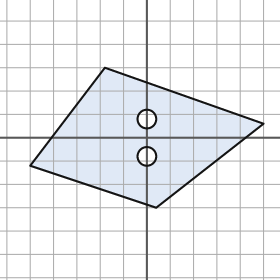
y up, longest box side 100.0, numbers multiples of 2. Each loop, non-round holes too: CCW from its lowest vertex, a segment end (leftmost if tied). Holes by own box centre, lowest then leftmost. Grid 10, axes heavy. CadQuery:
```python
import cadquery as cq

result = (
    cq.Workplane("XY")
    .moveTo(4.0, -30.0)
    .lineTo(50.0, 6.0)
    .lineTo(-18.0, 30.0)
    .lineTo(-50.0, -12.0)
    .close()
    .moveTo(0.0, -8.0)
    .circle(4.0)
    .moveTo(0.0, 8.0)
    .circle(4.0)
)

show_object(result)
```